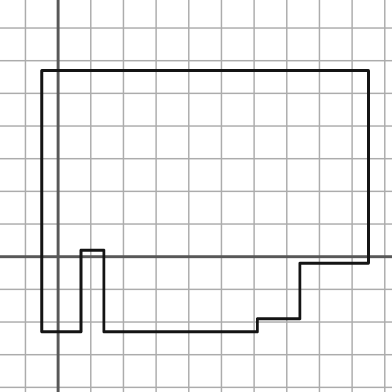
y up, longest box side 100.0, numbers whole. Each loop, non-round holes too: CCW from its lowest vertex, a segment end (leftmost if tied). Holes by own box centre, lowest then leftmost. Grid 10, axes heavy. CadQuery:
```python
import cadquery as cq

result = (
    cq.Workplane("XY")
    .moveTo(-5.0, -23.0)
    .lineTo(7.0, -23.0)
    .lineTo(7.0, 2.0)
    .lineTo(14.0, 2.0)
    .lineTo(14.0, -23.0)
    .lineTo(61.0, -23.0)
    .lineTo(61.0, -19.0)
    .lineTo(74.0, -19.0)
    .lineTo(74.0, -2.0)
    .lineTo(95.0, -2.0)
    .lineTo(95.0, 57.0)
    .lineTo(-5.0, 57.0)
    .close()
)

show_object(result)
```